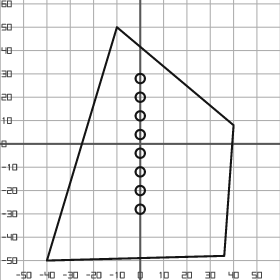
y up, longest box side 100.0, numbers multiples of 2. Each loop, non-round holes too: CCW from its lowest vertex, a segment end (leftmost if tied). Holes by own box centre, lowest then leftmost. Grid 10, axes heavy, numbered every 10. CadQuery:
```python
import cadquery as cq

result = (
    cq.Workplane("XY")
    .moveTo(-40.0, -50.0)
    .lineTo(36.0, -48.0)
    .lineTo(40.0, 8.0)
    .lineTo(-10.0, 50.0)
    .close()
    .moveTo(0.0, -28.0)
    .circle(2.0)
    .moveTo(0.0, -20.0)
    .circle(2.0)
    .moveTo(0.0, -12.0)
    .circle(2.0)
    .moveTo(0.0, -4.0)
    .circle(2.0)
    .moveTo(0.0, 4.0)
    .circle(2.0)
    .moveTo(0.0, 12.0)
    .circle(2.0)
    .moveTo(0.0, 20.0)
    .circle(2.0)
    .moveTo(0.0, 28.0)
    .circle(2.0)
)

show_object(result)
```